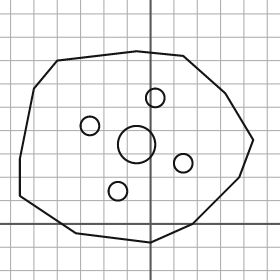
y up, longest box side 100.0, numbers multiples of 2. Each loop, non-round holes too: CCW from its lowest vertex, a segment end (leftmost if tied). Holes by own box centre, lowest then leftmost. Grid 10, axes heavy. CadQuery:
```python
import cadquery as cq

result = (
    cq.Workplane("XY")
    .moveTo(0.0, -8.0)
    .lineTo(18.0, 0.0)
    .lineTo(38.0, 20.0)
    .lineTo(44.0, 36.0)
    .lineTo(32.0, 56.0)
    .lineTo(14.0, 72.0)
    .lineTo(-6.0, 74.0)
    .lineTo(-40.0, 70.0)
    .lineTo(-50.0, 58.0)
    .lineTo(-56.0, 28.0)
    .lineTo(-56.0, 12.0)
    .lineTo(-32.0, -4.0)
    .close()
    .moveTo(-14.0, 14.0)
    .circle(4.0)
    .moveTo(14.0, 26.0)
    .circle(4.0)
    .moveTo(-6.0, 34.0)
    .circle(8.0)
    .moveTo(-26.0, 42.0)
    .circle(4.0)
    .moveTo(2.0, 54.0)
    .circle(4.0)
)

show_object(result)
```